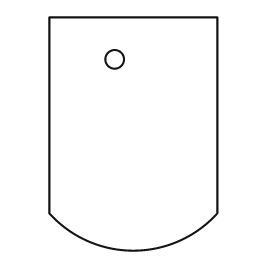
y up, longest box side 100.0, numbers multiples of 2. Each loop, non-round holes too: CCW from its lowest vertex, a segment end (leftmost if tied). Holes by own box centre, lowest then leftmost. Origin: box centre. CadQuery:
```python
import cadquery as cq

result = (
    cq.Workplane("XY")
    .moveTo(-36.0, -34.0)
    .threePointArc((0.0, -50.0), (36.0, -34.0))
    .lineTo(36.0, 50.0)
    .lineTo(-36.0, 50.0)
    .close()
    .moveTo(-8.0, 32.0)
    .circle(4.0)
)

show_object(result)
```